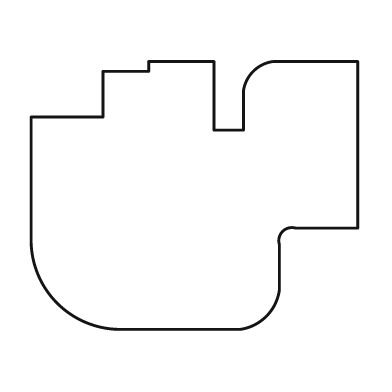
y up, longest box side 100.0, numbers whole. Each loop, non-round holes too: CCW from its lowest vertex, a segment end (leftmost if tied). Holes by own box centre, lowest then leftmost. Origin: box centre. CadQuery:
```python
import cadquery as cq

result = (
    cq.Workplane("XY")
    .moveTo(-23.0, -41.0)
    .lineTo(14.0, -41.0)
    .threePointArc((22.0, -37.0), (26.0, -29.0))
    .lineTo(26.0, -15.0)
    .threePointArc((27.0, -11.0), (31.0, -10.0))
    .lineTo(50.0, -10.0)
    .lineTo(50.0, 41.0)
    .lineTo(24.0, 41.0)
    .threePointArc((18.0, 38.0), (15.0, 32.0))
    .lineTo(15.0, 20.0)
    .lineTo(6.0, 20.0)
    .lineTo(6.0, 41.0)
    .lineTo(-14.0, 41.0)
    .lineTo(-14.0, 38.0)
    .lineTo(-28.0, 38.0)
    .lineTo(-28.0, 24.0)
    .lineTo(-50.0, 24.0)
    .lineTo(-50.0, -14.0)
    .threePointArc((-42.0, -33.0), (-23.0, -41.0))
    .close()
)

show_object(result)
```